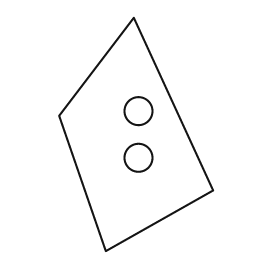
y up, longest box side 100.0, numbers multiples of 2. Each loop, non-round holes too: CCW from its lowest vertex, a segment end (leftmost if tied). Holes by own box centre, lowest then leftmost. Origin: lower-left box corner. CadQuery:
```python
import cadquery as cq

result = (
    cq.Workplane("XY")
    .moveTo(20.0, 0.0)
    .lineTo(66.0, 26.0)
    .lineTo(32.0, 100.0)
    .lineTo(0.0, 58.0)
    .close()
    .moveTo(34.0, 40.0)
    .circle(6.0)
    .moveTo(34.0, 60.0)
    .circle(6.0)
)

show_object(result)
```